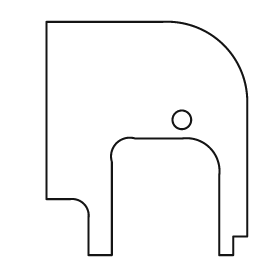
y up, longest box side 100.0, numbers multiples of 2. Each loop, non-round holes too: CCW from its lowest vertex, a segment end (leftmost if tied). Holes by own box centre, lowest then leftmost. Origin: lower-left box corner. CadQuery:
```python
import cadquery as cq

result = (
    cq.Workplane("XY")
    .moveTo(18.0, 0.0)
    .lineTo(28.0, 0.0)
    .lineTo(28.0, 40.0)
    .threePointArc((30.0, 48.0), (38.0, 50.0))
    .lineTo(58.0, 50.0)
    .threePointArc((70.0, 46.0), (74.0, 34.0))
    .lineTo(74.0, 0.0)
    .lineTo(80.0, 0.0)
    .lineTo(80.0, 8.0)
    .lineTo(86.0, 8.0)
    .lineTo(86.0, 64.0)
    .threePointArc((76.0, 90.0), (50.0, 100.0))
    .lineTo(0.0, 100.0)
    .lineTo(0.0, 24.0)
    .lineTo(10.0, 24.0)
    .threePointArc((16.0, 22.0), (18.0, 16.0))
    .close()
    .moveTo(58.0, 58.0)
    .circle(4.0)
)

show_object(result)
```